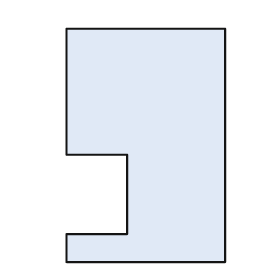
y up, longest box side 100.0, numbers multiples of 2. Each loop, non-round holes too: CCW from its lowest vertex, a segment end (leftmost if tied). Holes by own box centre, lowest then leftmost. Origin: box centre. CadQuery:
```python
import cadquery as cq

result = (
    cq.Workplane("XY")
    .moveTo(-34.0, -50.0)
    .lineTo(34.0, -50.0)
    .lineTo(34.0, 50.0)
    .lineTo(-34.0, 50.0)
    .lineTo(-34.0, -4.0)
    .lineTo(-8.0, -4.0)
    .lineTo(-8.0, -38.0)
    .lineTo(-34.0, -38.0)
    .close()
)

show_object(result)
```